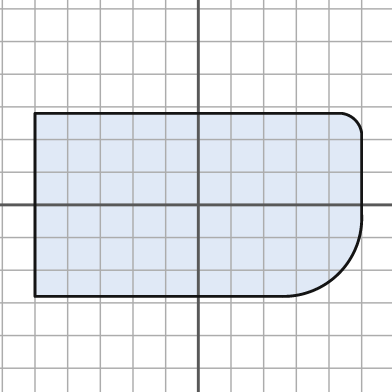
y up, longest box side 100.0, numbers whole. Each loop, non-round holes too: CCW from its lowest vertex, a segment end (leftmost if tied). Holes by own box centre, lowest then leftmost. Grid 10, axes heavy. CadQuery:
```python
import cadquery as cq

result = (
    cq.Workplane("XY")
    .moveTo(-50.0, -28.0)
    .lineTo(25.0, -28.0)
    .threePointArc((43.0, -21.0), (50.0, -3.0))
    .lineTo(50.0, 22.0)
    .threePointArc((48.0, 26.0), (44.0, 28.0))
    .lineTo(-50.0, 28.0)
    .close()
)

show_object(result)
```